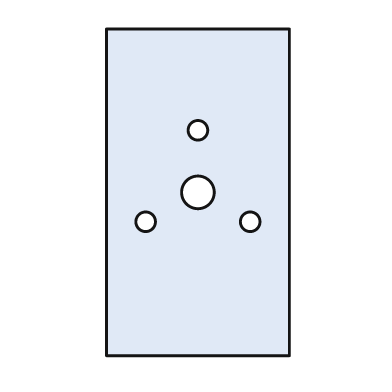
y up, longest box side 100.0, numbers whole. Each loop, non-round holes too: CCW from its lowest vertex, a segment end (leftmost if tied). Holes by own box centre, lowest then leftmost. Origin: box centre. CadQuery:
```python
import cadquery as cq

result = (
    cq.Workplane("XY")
    .moveTo(-28.0, -50.0)
    .lineTo(28.0, -50.0)
    .lineTo(28.0, 50.0)
    .lineTo(-28.0, 50.0)
    .close()
    .moveTo(-16.0, -9.0)
    .circle(3.0)
    .moveTo(16.0, -9.0)
    .circle(3.0)
    .moveTo(0.0, 0.0)
    .circle(5.0)
    .moveTo(0.0, 19.0)
    .circle(3.0)
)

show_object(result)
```